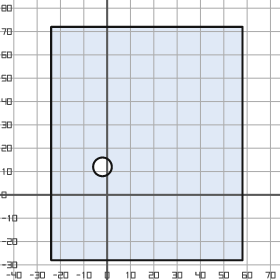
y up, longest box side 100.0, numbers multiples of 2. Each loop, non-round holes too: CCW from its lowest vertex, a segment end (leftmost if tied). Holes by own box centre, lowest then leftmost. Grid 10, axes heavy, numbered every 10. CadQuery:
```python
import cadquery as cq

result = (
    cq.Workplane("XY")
    .moveTo(-24.0, -28.0)
    .lineTo(58.0, -28.0)
    .lineTo(58.0, 72.0)
    .lineTo(-24.0, 72.0)
    .close()
    .moveTo(-2.0, 12.0)
    .circle(4.0)
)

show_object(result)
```